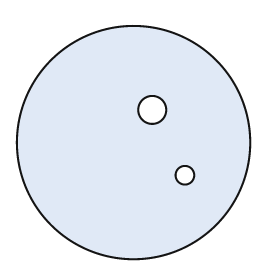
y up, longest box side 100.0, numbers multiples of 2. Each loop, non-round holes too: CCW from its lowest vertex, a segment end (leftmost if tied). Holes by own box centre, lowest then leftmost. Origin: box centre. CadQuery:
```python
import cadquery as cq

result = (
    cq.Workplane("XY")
    .moveTo(0.0, 0.0)
    .circle(50.0)
    .moveTo(22.0, -14.0)
    .circle(4.0)
    .moveTo(8.0, 14.0)
    .circle(6.0)
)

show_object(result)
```